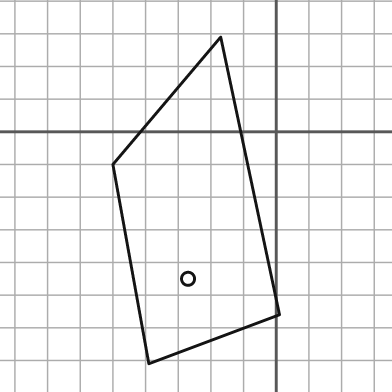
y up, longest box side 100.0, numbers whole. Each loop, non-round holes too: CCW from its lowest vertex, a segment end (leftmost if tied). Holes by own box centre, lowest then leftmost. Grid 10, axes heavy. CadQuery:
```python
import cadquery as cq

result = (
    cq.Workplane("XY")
    .moveTo(-39.0, -71.0)
    .lineTo(1.0, -56.0)
    .lineTo(-17.0, 29.0)
    .lineTo(-50.0, -10.0)
    .close()
    .moveTo(-27.0, -45.0)
    .circle(2.0)
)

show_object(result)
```